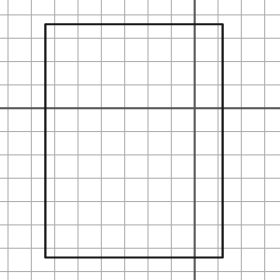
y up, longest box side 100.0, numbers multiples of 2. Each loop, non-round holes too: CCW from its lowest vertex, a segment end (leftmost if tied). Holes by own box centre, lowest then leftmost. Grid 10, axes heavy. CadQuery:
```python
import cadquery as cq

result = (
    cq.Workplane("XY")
    .moveTo(-64.0, -64.0)
    .lineTo(12.0, -64.0)
    .lineTo(12.0, 36.0)
    .lineTo(-64.0, 36.0)
    .close()
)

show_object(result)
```